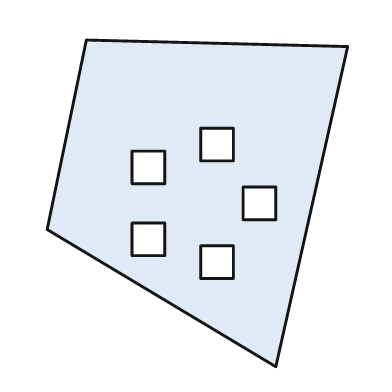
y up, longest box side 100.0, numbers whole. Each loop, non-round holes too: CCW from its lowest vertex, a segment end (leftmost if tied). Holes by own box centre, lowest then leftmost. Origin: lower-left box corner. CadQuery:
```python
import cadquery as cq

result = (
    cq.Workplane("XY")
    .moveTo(70.0, 0.0)
    .lineTo(92.0, 98.0)
    .lineTo(12.0, 100.0)
    .lineTo(0.0, 42.0)
    .close()
    .moveTo(47.0, 27.0)
    .lineTo(57.0, 27.0)
    .lineTo(57.0, 37.0)
    .lineTo(47.0, 37.0)
    .close()
    .moveTo(26.0, 34.0)
    .lineTo(36.0, 34.0)
    .lineTo(36.0, 44.0)
    .lineTo(26.0, 44.0)
    .close()
    .moveTo(60.0, 45.0)
    .lineTo(70.0, 45.0)
    .lineTo(70.0, 55.0)
    .lineTo(60.0, 55.0)
    .close()
    .moveTo(26.0, 56.0)
    .lineTo(36.0, 56.0)
    .lineTo(36.0, 66.0)
    .lineTo(26.0, 66.0)
    .close()
    .moveTo(47.0, 63.0)
    .lineTo(57.0, 63.0)
    .lineTo(57.0, 73.0)
    .lineTo(47.0, 73.0)
    .close()
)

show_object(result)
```